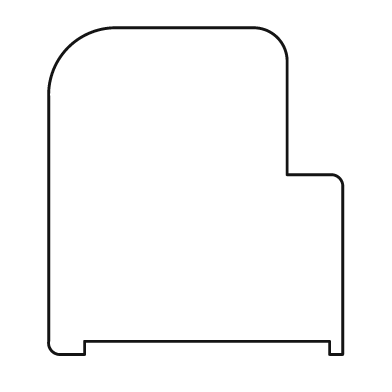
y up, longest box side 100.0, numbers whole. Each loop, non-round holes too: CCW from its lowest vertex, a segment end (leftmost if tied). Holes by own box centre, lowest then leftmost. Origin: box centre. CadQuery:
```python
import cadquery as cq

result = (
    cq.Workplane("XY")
    .moveTo(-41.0, -50.0)
    .lineTo(-34.0, -50.0)
    .lineTo(-34.0, -46.0)
    .lineTo(41.0, -46.0)
    .lineTo(41.0, -50.0)
    .lineTo(45.0, -50.0)
    .lineTo(45.0, 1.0)
    .threePointArc((44.0, 4.0), (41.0, 5.0))
    .lineTo(28.0, 5.0)
    .lineTo(28.0, 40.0)
    .threePointArc((25.0, 47.0), (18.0, 50.0))
    .lineTo(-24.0, 50.0)
    .threePointArc((-39.0, 44.0), (-45.0, 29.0))
    .lineTo(-45.0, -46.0)
    .threePointArc((-44.0, -49.0), (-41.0, -50.0))
    .close()
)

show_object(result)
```